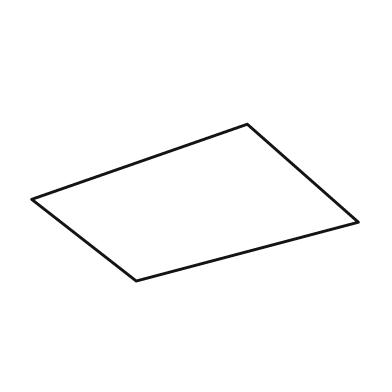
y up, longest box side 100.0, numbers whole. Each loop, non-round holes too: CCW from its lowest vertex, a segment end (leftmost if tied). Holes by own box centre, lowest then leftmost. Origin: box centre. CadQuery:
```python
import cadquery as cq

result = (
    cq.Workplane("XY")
    .moveTo(-18.0, -24.0)
    .lineTo(50.0, -6.0)
    .lineTo(16.0, 24.0)
    .lineTo(-50.0, 1.0)
    .close()
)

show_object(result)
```